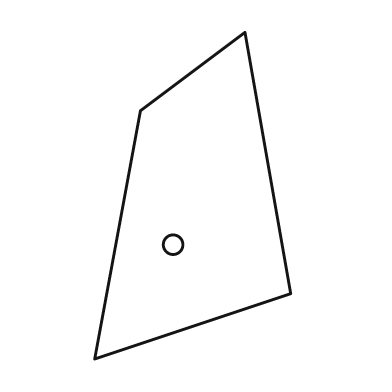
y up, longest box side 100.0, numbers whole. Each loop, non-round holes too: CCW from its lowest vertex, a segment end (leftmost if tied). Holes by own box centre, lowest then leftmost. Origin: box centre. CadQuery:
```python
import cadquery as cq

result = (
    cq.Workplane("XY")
    .moveTo(-30.0, -50.0)
    .lineTo(30.0, -30.0)
    .lineTo(16.0, 50.0)
    .lineTo(-16.0, 26.0)
    .close()
    .moveTo(-6.0, -15.0)
    .circle(3.0)
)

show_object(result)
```